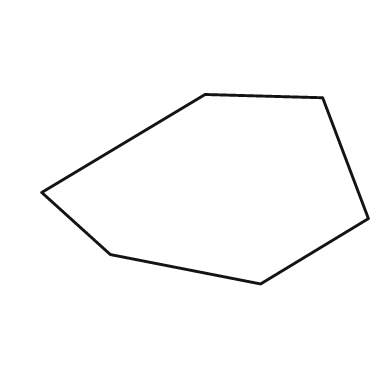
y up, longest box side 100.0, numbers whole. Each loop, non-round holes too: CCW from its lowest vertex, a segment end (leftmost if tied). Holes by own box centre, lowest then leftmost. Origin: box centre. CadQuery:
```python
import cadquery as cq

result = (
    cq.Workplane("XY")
    .moveTo(17.0, -29.0)
    .lineTo(50.0, -9.0)
    .lineTo(36.0, 28.0)
    .lineTo(0.0, 29.0)
    .lineTo(-50.0, -1.0)
    .lineTo(-29.0, -20.0)
    .close()
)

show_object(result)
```